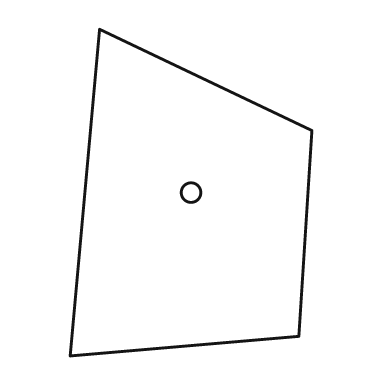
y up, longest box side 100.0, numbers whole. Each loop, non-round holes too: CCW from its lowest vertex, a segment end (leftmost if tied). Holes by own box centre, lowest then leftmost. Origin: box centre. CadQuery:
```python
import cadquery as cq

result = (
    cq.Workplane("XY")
    .moveTo(-37.0, -50.0)
    .lineTo(33.0, -44.0)
    .lineTo(37.0, 19.0)
    .lineTo(-28.0, 50.0)
    .close()
    .moveTo(0.0, 0.0)
    .circle(3.0)
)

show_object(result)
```